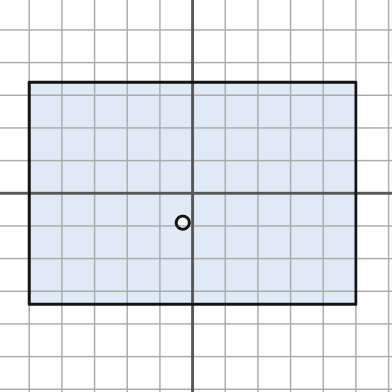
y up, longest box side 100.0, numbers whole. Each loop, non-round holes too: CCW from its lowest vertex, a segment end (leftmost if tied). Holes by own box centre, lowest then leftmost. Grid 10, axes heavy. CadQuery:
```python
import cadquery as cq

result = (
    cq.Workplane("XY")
    .moveTo(-50.0, -34.0)
    .lineTo(50.0, -34.0)
    .lineTo(50.0, 34.0)
    .lineTo(-50.0, 34.0)
    .close()
    .moveTo(-3.0, -9.0)
    .circle(2.0)
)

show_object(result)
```